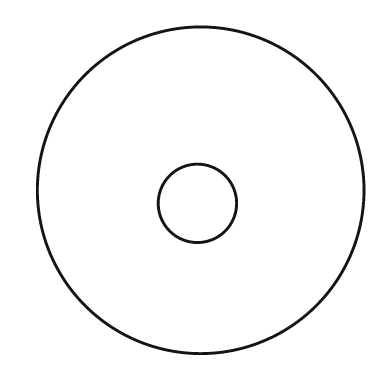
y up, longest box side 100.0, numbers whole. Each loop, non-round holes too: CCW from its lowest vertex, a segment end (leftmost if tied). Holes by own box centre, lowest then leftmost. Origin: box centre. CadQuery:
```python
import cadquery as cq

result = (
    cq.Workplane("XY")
    .moveTo(0.0, 0.0)
    .circle(50.0)
    .moveTo(-1.0, -4.0)
    .circle(12.0)
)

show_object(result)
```